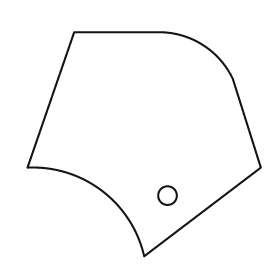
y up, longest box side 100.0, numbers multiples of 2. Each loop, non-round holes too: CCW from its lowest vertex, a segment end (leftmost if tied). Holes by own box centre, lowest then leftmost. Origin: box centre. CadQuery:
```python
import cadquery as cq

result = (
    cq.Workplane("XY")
    .moveTo(0.0, -48.0)
    .lineTo(50.0, -10.0)
    .lineTo(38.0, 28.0)
    .threePointArc((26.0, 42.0), (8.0, 48.0))
    .lineTo(-30.0, 48.0)
    .lineTo(-50.0, -10.0)
    .threePointArc((-18.0, -20.0), (0.0, -48.0))
    .close()
    .moveTo(10.0, -22.0)
    .circle(4.0)
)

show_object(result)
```